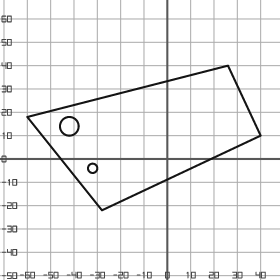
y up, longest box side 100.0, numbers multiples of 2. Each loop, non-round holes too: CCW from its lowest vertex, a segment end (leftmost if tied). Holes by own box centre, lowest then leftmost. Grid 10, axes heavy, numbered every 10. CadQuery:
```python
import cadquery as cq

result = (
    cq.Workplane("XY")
    .moveTo(-28.0, -22.0)
    .lineTo(40.0, 10.0)
    .lineTo(26.0, 40.0)
    .lineTo(-60.0, 18.0)
    .close()
    .moveTo(-32.0, -4.0)
    .circle(2.0)
    .moveTo(-42.0, 14.0)
    .circle(4.0)
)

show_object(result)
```